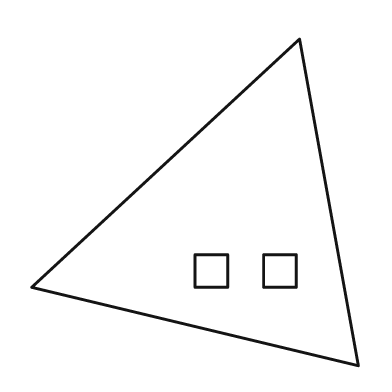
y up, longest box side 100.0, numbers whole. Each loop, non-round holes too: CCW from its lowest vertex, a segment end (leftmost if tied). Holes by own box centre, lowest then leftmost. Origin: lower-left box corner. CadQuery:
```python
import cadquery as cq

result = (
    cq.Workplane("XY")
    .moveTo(100.0, 0.0)
    .lineTo(82.0, 100.0)
    .lineTo(0.0, 24.0)
    .close()
    .moveTo(50.0, 24.0)
    .lineTo(60.0, 24.0)
    .lineTo(60.0, 34.0)
    .lineTo(50.0, 34.0)
    .close()
    .moveTo(71.0, 24.0)
    .lineTo(81.0, 24.0)
    .lineTo(81.0, 34.0)
    .lineTo(71.0, 34.0)
    .close()
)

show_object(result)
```